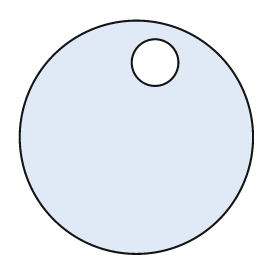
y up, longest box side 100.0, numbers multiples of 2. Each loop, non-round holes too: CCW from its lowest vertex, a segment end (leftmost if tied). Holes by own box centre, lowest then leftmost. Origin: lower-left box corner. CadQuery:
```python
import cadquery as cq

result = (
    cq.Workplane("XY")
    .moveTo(50.0, 50.0)
    .circle(50.0)
    .moveTo(58.0, 82.0)
    .circle(10.0)
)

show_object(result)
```